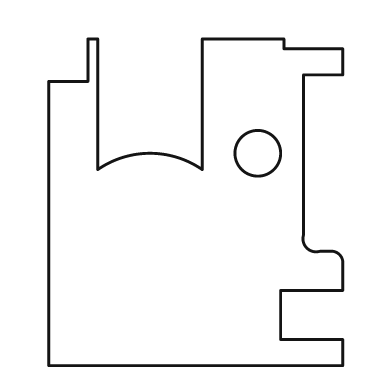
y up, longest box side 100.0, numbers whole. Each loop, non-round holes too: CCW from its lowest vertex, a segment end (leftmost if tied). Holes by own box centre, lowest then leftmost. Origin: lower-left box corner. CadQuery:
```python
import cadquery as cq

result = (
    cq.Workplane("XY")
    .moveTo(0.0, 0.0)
    .lineTo(90.0, 0.0)
    .lineTo(90.0, 8.0)
    .lineTo(71.0, 8.0)
    .lineTo(71.0, 23.0)
    .lineTo(90.0, 23.0)
    .lineTo(90.0, 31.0)
    .threePointArc((89.0, 34.0), (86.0, 35.0))
    .lineTo(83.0, 35.0)
    .threePointArc((79.0, 36.0), (78.0, 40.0))
    .lineTo(78.0, 89.0)
    .lineTo(90.0, 89.0)
    .lineTo(90.0, 97.0)
    .lineTo(72.0, 97.0)
    .lineTo(72.0, 100.0)
    .lineTo(47.0, 100.0)
    .lineTo(47.0, 60.0)
    .threePointArc((31.0, 65.0), (15.0, 60.0))
    .lineTo(15.0, 100.0)
    .lineTo(12.0, 100.0)
    .lineTo(12.0, 87.0)
    .lineTo(0.0, 87.0)
    .close()
    .moveTo(64.0, 65.0)
    .circle(7.0)
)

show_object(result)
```